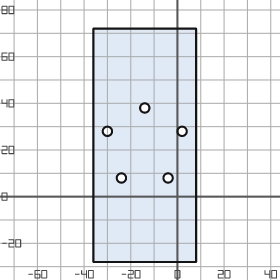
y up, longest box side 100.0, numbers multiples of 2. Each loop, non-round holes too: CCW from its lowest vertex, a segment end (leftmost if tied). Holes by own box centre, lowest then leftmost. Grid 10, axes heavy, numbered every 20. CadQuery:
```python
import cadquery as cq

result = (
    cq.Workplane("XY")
    .moveTo(-36.0, -28.0)
    .lineTo(8.0, -28.0)
    .lineTo(8.0, 72.0)
    .lineTo(-36.0, 72.0)
    .close()
    .moveTo(-24.0, 8.0)
    .circle(2.0)
    .moveTo(-4.0, 8.0)
    .circle(2.0)
    .moveTo(-30.0, 28.0)
    .circle(2.0)
    .moveTo(2.0, 28.0)
    .circle(2.0)
    .moveTo(-14.0, 38.0)
    .circle(2.0)
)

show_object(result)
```